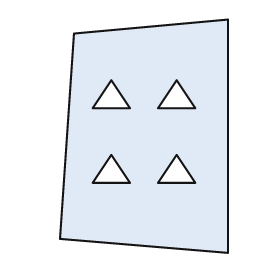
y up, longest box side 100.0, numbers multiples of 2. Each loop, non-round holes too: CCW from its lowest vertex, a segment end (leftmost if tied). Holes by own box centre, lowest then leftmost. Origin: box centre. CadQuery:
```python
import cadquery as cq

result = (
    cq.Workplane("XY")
    .moveTo(36.0, -50.0)
    .lineTo(36.0, 50.0)
    .lineTo(-30.0, 44.0)
    .lineTo(-36.0, -44.0)
    .close()
    .moveTo(-22.0, -20.0)
    .lineTo(-6.0, -20.0)
    .lineTo(-14.0, -8.0)
    .close()
    .moveTo(6.0, -20.0)
    .lineTo(22.0, -20.0)
    .lineTo(14.0, -8.0)
    .close()
    .moveTo(-22.0, 12.0)
    .lineTo(-6.0, 12.0)
    .lineTo(-14.0, 24.0)
    .close()
    .moveTo(6.0, 12.0)
    .lineTo(22.0, 12.0)
    .lineTo(14.0, 24.0)
    .close()
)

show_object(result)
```